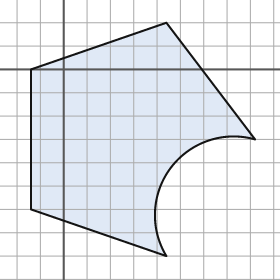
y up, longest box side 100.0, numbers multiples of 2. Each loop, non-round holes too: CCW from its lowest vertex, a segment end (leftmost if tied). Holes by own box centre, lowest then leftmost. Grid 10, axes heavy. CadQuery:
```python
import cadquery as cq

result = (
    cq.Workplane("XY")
    .moveTo(44.0, -80.0)
    .threePointArc((46.0, -42.0), (82.0, -30.0))
    .lineTo(44.0, 20.0)
    .lineTo(-14.0, 0.0)
    .lineTo(-14.0, -60.0)
    .close()
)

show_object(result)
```